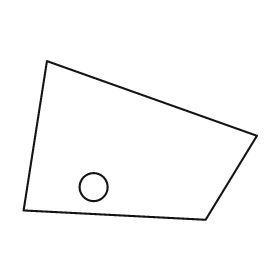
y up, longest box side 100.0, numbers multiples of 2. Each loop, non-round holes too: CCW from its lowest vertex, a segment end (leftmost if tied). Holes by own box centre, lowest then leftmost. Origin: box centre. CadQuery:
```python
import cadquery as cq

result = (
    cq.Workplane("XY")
    .moveTo(28.0, -34.0)
    .lineTo(50.0, 2.0)
    .lineTo(-40.0, 34.0)
    .lineTo(-50.0, -30.0)
    .close()
    .moveTo(-20.0, -20.0)
    .circle(6.0)
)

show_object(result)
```